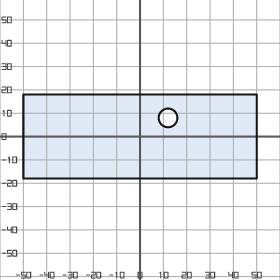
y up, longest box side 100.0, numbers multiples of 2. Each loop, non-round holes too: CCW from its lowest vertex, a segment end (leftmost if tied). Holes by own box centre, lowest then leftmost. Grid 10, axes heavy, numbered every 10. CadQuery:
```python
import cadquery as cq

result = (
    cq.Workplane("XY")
    .moveTo(-50.0, -18.0)
    .lineTo(50.0, -18.0)
    .lineTo(50.0, 18.0)
    .lineTo(-50.0, 18.0)
    .close()
    .moveTo(12.0, 8.0)
    .circle(4.0)
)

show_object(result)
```